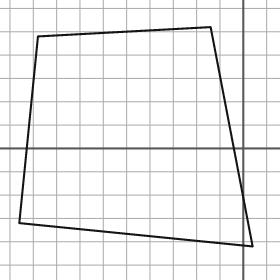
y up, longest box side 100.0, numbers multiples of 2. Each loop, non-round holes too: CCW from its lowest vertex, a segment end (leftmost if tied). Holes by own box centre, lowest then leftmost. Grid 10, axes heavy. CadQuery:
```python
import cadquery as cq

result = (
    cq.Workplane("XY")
    .moveTo(4.0, -42.0)
    .lineTo(-14.0, 52.0)
    .lineTo(-88.0, 48.0)
    .lineTo(-96.0, -32.0)
    .close()
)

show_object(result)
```